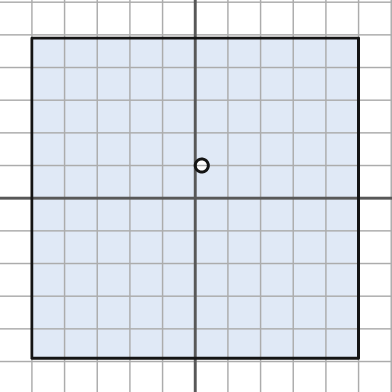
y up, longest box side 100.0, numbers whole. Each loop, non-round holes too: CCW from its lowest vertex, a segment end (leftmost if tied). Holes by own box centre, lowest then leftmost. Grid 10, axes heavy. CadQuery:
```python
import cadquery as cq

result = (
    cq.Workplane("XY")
    .moveTo(-50.0, -49.0)
    .lineTo(50.0, -49.0)
    .lineTo(50.0, 49.0)
    .lineTo(-50.0, 49.0)
    .close()
    .moveTo(2.0, 10.0)
    .circle(2.0)
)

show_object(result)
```